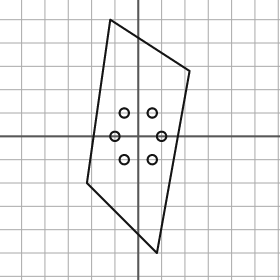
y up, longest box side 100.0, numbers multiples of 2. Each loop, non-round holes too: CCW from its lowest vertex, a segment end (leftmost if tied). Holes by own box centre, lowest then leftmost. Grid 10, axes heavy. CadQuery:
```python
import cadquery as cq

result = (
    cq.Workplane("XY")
    .moveTo(8.0, -50.0)
    .lineTo(22.0, 28.0)
    .lineTo(-12.0, 50.0)
    .lineTo(-22.0, -20.0)
    .close()
    .moveTo(-6.0, -10.0)
    .circle(2.0)
    .moveTo(6.0, -10.0)
    .circle(2.0)
    .moveTo(-10.0, 0.0)
    .circle(2.0)
    .moveTo(10.0, 0.0)
    .circle(2.0)
    .moveTo(-6.0, 10.0)
    .circle(2.0)
    .moveTo(6.0, 10.0)
    .circle(2.0)
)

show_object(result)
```